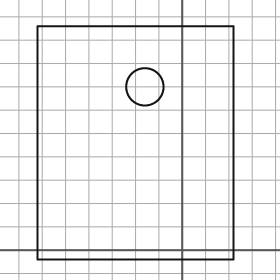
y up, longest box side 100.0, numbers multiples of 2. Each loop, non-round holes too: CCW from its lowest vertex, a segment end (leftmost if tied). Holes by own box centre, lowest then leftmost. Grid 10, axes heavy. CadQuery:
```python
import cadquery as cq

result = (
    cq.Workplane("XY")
    .moveTo(-62.0, -4.0)
    .lineTo(22.0, -4.0)
    .lineTo(22.0, 96.0)
    .lineTo(-62.0, 96.0)
    .close()
    .moveTo(-16.0, 70.0)
    .circle(8.0)
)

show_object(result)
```